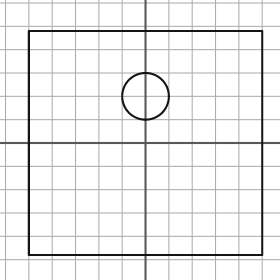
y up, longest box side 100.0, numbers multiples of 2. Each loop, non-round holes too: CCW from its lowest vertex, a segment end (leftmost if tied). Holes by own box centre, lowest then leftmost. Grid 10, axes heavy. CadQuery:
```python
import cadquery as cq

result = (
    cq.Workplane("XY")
    .moveTo(-50.0, -48.0)
    .lineTo(50.0, -48.0)
    .lineTo(50.0, 48.0)
    .lineTo(-50.0, 48.0)
    .close()
    .moveTo(0.0, 20.0)
    .circle(10.0)
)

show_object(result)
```